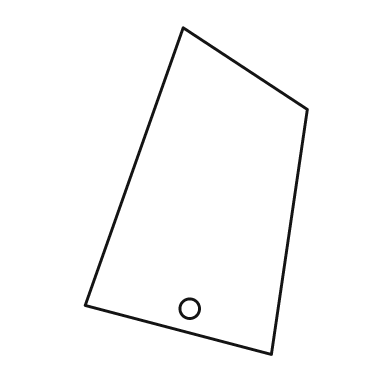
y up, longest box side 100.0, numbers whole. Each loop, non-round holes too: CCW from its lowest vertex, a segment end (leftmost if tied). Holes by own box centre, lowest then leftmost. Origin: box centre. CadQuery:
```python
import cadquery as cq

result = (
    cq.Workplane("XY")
    .moveTo(23.0, -50.0)
    .lineTo(34.0, 25.0)
    .lineTo(-4.0, 50.0)
    .lineTo(-34.0, -35.0)
    .close()
    .moveTo(-2.0, -36.0)
    .circle(3.0)
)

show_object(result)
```